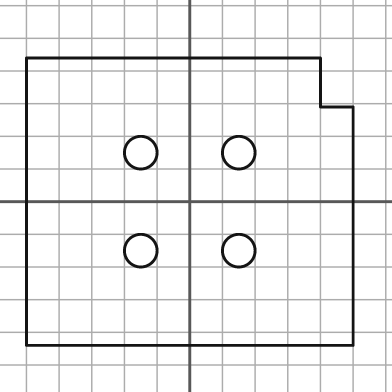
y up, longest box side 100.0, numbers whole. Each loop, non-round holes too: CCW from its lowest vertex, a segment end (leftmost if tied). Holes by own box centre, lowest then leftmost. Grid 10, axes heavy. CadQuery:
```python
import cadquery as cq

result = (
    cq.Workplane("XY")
    .moveTo(-50.0, -44.0)
    .lineTo(50.0, -44.0)
    .lineTo(50.0, 29.0)
    .lineTo(40.0, 29.0)
    .lineTo(40.0, 44.0)
    .lineTo(-50.0, 44.0)
    .close()
    .moveTo(-15.0, -15.0)
    .circle(5.0)
    .moveTo(15.0, -15.0)
    .circle(5.0)
    .moveTo(-15.0, 15.0)
    .circle(5.0)
    .moveTo(15.0, 15.0)
    .circle(5.0)
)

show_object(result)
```